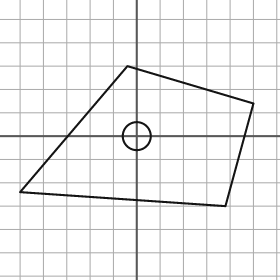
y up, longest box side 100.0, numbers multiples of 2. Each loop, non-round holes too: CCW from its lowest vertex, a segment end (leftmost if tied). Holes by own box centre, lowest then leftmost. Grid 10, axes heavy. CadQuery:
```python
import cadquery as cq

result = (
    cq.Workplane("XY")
    .moveTo(38.0, -30.0)
    .lineTo(50.0, 14.0)
    .lineTo(-4.0, 30.0)
    .lineTo(-50.0, -24.0)
    .close()
    .moveTo(0.0, 0.0)
    .circle(6.0)
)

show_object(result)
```